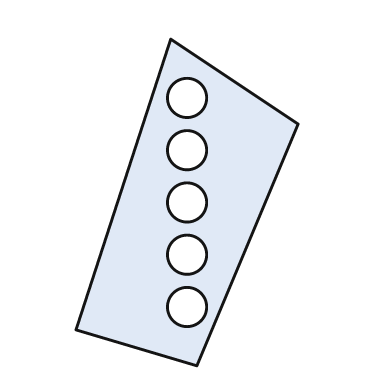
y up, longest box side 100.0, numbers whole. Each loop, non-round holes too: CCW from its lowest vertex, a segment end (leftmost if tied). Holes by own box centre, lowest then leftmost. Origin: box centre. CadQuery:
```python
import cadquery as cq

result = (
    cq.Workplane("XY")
    .moveTo(3.0, -50.0)
    .lineTo(34.0, 24.0)
    .lineTo(-5.0, 50.0)
    .lineTo(-34.0, -39.0)
    .close()
    .moveTo(0.0, -32.0)
    .circle(6.0)
    .moveTo(0.0, -16.0)
    .circle(6.0)
    .moveTo(0.0, 0.0)
    .circle(6.0)
    .moveTo(0.0, 16.0)
    .circle(6.0)
    .moveTo(0.0, 32.0)
    .circle(6.0)
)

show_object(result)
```